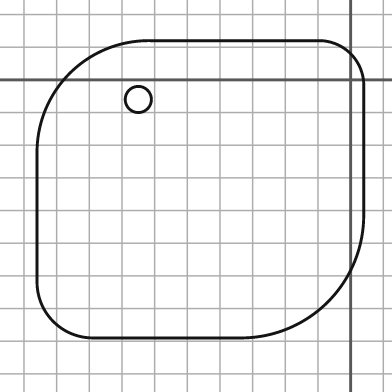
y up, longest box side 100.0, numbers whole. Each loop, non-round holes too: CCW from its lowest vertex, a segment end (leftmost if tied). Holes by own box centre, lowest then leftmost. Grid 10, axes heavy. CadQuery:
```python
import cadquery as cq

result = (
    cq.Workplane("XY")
    .moveTo(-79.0, -79.0)
    .lineTo(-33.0, -79.0)
    .threePointArc((-7.0, -68.0), (4.0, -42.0))
    .lineTo(4.0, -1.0)
    .threePointArc((0.0, 8.0), (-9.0, 12.0))
    .lineTo(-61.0, 12.0)
    .threePointArc((-86.0, 2.0), (-96.0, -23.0))
    .lineTo(-96.0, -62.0)
    .threePointArc((-91.0, -74.0), (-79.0, -79.0))
    .close()
    .moveTo(-65.0, -6.0)
    .circle(4.0)
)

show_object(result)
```